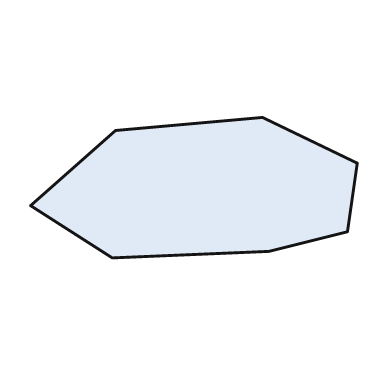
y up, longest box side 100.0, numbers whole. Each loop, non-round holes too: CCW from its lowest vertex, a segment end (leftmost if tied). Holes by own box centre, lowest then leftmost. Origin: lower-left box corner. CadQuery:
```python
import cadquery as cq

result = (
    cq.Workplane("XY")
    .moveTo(25.0, 0.0)
    .lineTo(73.0, 2.0)
    .lineTo(97.0, 8.0)
    .lineTo(100.0, 29.0)
    .lineTo(71.0, 43.0)
    .lineTo(26.0, 39.0)
    .lineTo(0.0, 16.0)
    .close()
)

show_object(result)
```